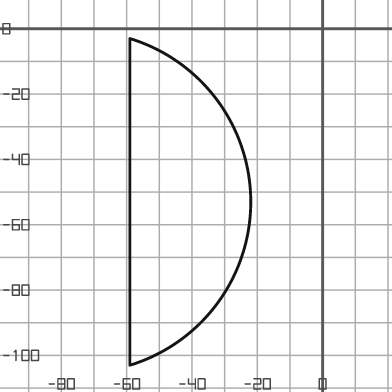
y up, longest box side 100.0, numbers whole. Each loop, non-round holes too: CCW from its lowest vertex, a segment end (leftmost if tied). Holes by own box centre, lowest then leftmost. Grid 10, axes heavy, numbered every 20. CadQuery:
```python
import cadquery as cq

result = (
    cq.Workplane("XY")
    .moveTo(-59.0, -103.0)
    .threePointArc((-22.0, -53.0), (-59.0, -3.0))
    .close()
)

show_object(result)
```